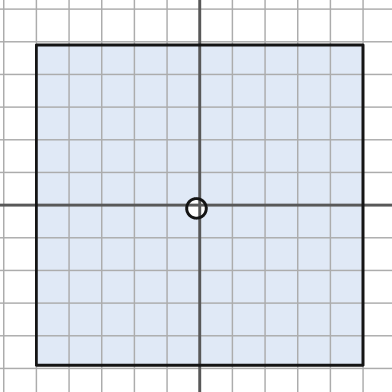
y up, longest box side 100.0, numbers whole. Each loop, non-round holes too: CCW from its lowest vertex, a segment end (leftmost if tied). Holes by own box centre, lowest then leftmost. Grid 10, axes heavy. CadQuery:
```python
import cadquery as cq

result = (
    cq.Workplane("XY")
    .moveTo(-50.0, -49.0)
    .lineTo(50.0, -49.0)
    .lineTo(50.0, 49.0)
    .lineTo(-50.0, 49.0)
    .close()
    .moveTo(-1.0, -1.0)
    .circle(3.0)
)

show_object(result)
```